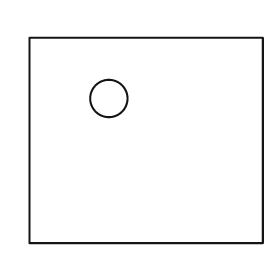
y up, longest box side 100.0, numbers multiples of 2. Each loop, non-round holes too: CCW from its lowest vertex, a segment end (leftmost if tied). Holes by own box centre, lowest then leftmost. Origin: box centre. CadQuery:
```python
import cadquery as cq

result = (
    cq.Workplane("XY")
    .moveTo(-50.0, -44.0)
    .lineTo(50.0, -44.0)
    .lineTo(50.0, 44.0)
    .lineTo(-50.0, 44.0)
    .close()
    .moveTo(-16.0, 18.0)
    .circle(8.0)
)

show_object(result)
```